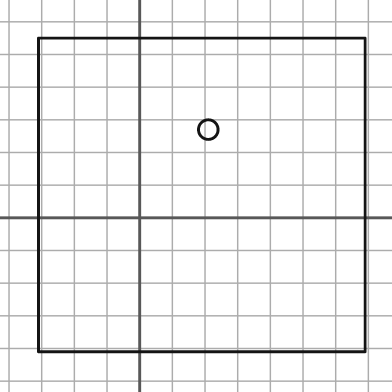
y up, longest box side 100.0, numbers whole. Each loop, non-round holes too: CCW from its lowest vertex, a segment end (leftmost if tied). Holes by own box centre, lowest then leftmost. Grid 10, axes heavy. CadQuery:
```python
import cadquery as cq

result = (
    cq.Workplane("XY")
    .moveTo(-31.0, -41.0)
    .lineTo(69.0, -41.0)
    .lineTo(69.0, 55.0)
    .lineTo(-31.0, 55.0)
    .close()
    .moveTo(21.0, 27.0)
    .circle(3.0)
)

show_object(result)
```